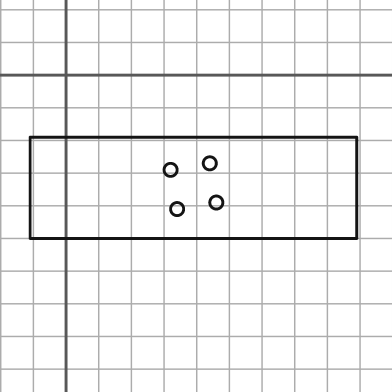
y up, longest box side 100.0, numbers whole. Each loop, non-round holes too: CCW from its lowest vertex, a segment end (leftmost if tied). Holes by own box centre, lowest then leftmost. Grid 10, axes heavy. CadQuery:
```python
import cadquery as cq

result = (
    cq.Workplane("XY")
    .moveTo(-11.0, -50.0)
    .lineTo(89.0, -50.0)
    .lineTo(89.0, -19.0)
    .lineTo(-11.0, -19.0)
    .close()
    .moveTo(34.0, -41.0)
    .circle(2.0)
    .moveTo(46.0, -39.0)
    .circle(2.0)
    .moveTo(32.0, -29.0)
    .circle(2.0)
    .moveTo(44.0, -27.0)
    .circle(2.0)
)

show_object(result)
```